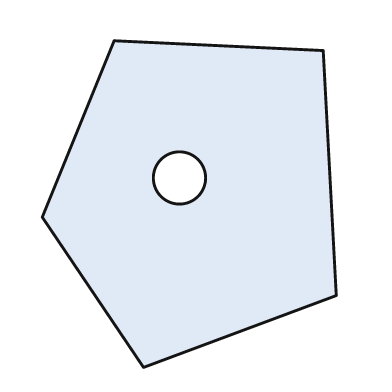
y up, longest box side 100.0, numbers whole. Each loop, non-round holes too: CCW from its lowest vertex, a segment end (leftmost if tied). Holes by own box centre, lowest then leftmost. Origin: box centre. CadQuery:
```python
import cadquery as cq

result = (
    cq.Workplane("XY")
    .moveTo(-14.0, -50.0)
    .lineTo(45.0, -28.0)
    .lineTo(41.0, 47.0)
    .lineTo(-23.0, 50.0)
    .lineTo(-45.0, -4.0)
    .close()
    .moveTo(-3.0, 8.0)
    .circle(8.0)
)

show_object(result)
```